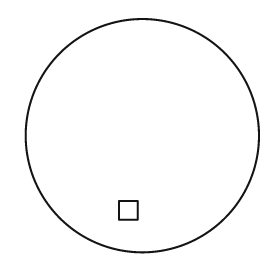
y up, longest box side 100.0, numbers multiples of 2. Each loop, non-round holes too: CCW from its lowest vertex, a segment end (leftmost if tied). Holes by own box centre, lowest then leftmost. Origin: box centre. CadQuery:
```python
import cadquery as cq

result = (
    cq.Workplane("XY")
    .moveTo(0.0, 0.0)
    .circle(50.0)
    .moveTo(-10.0, -36.0)
    .lineTo(-2.0, -36.0)
    .lineTo(-2.0, -28.0)
    .lineTo(-10.0, -28.0)
    .close()
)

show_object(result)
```